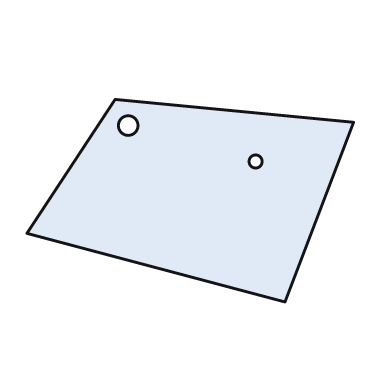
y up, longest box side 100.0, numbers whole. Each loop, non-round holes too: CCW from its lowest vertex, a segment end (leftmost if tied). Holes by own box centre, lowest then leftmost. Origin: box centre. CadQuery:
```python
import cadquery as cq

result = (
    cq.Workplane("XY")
    .moveTo(29.0, -31.0)
    .lineTo(50.0, 24.0)
    .lineTo(-23.0, 31.0)
    .lineTo(-50.0, -10.0)
    .close()
    .moveTo(20.0, 12.0)
    .circle(2.0)
    .moveTo(-19.0, 23.0)
    .circle(3.0)
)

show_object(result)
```